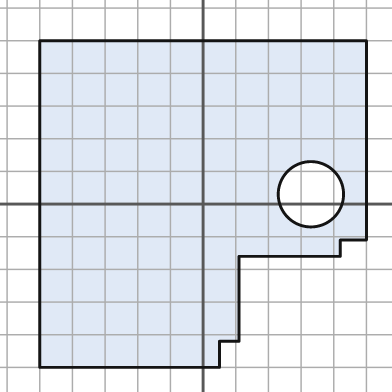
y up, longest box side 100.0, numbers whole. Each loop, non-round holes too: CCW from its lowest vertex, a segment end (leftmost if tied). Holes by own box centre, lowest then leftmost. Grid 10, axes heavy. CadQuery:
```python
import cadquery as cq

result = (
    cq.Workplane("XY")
    .moveTo(-50.0, -50.0)
    .lineTo(5.0, -50.0)
    .lineTo(5.0, -42.0)
    .lineTo(11.0, -42.0)
    .lineTo(11.0, -16.0)
    .lineTo(42.0, -16.0)
    .lineTo(42.0, -11.0)
    .lineTo(50.0, -11.0)
    .lineTo(50.0, 50.0)
    .lineTo(-50.0, 50.0)
    .close()
    .moveTo(33.0, 3.0)
    .circle(10.0)
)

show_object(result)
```